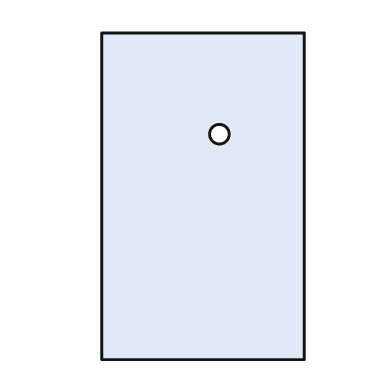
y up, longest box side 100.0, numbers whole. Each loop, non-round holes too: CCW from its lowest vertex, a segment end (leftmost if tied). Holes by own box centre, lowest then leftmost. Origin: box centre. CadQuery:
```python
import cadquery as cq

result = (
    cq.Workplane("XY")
    .moveTo(-31.0, -50.0)
    .lineTo(31.0, -50.0)
    .lineTo(31.0, 50.0)
    .lineTo(-31.0, 50.0)
    .close()
    .moveTo(5.0, 19.0)
    .circle(3.0)
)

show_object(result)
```